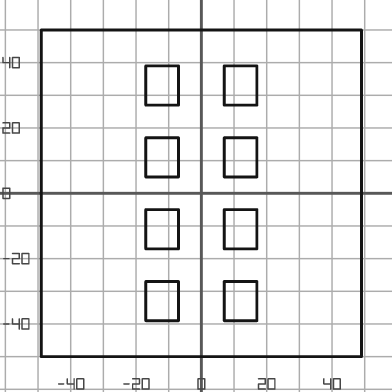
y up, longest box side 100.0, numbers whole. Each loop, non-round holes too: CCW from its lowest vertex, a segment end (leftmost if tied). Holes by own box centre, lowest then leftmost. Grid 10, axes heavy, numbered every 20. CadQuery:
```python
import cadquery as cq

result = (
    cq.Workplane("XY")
    .moveTo(-49.0, -50.0)
    .lineTo(49.0, -50.0)
    .lineTo(49.0, 50.0)
    .lineTo(-49.0, 50.0)
    .close()
    .moveTo(-17.0, -39.0)
    .lineTo(-7.0, -39.0)
    .lineTo(-7.0, -27.0)
    .lineTo(-17.0, -27.0)
    .close()
    .moveTo(7.0, -39.0)
    .lineTo(17.0, -39.0)
    .lineTo(17.0, -27.0)
    .lineTo(7.0, -27.0)
    .close()
    .moveTo(-17.0, -17.0)
    .lineTo(-7.0, -17.0)
    .lineTo(-7.0, -5.0)
    .lineTo(-17.0, -5.0)
    .close()
    .moveTo(7.0, -17.0)
    .lineTo(17.0, -17.0)
    .lineTo(17.0, -5.0)
    .lineTo(7.0, -5.0)
    .close()
    .moveTo(-17.0, 5.0)
    .lineTo(-7.0, 5.0)
    .lineTo(-7.0, 17.0)
    .lineTo(-17.0, 17.0)
    .close()
    .moveTo(7.0, 5.0)
    .lineTo(17.0, 5.0)
    .lineTo(17.0, 17.0)
    .lineTo(7.0, 17.0)
    .close()
    .moveTo(-17.0, 27.0)
    .lineTo(-7.0, 27.0)
    .lineTo(-7.0, 39.0)
    .lineTo(-17.0, 39.0)
    .close()
    .moveTo(7.0, 27.0)
    .lineTo(17.0, 27.0)
    .lineTo(17.0, 39.0)
    .lineTo(7.0, 39.0)
    .close()
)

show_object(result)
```